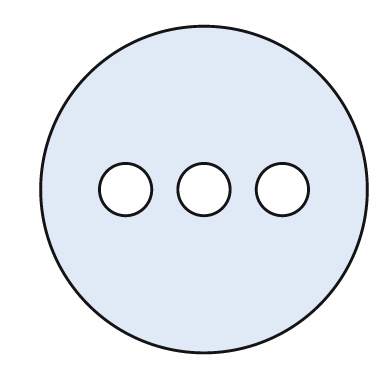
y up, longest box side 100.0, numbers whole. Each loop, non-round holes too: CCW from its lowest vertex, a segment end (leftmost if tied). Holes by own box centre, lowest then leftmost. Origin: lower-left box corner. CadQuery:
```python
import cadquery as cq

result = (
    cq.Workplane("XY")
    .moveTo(50.0, 50.0)
    .circle(50.0)
    .moveTo(26.0, 50.0)
    .circle(8.0)
    .moveTo(50.0, 50.0)
    .circle(8.0)
    .moveTo(74.0, 50.0)
    .circle(8.0)
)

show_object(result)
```